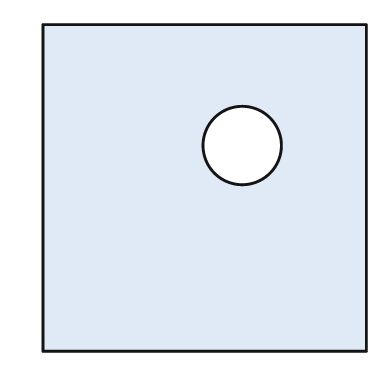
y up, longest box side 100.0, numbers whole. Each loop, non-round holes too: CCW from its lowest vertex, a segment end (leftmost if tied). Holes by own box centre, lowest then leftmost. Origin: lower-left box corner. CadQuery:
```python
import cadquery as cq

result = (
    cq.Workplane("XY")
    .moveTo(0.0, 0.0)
    .lineTo(99.0, 0.0)
    .lineTo(99.0, 100.0)
    .lineTo(0.0, 100.0)
    .close()
    .moveTo(61.0, 63.0)
    .circle(12.0)
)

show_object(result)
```